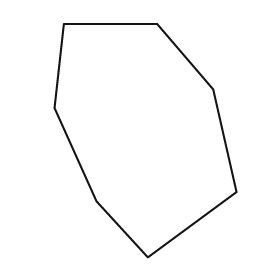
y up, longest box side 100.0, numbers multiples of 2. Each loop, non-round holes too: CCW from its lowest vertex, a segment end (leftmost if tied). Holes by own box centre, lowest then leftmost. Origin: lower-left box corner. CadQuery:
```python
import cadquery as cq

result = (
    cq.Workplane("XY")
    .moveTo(40.0, 0.0)
    .lineTo(78.0, 28.0)
    .lineTo(68.0, 72.0)
    .lineTo(44.0, 100.0)
    .lineTo(4.0, 100.0)
    .lineTo(0.0, 64.0)
    .lineTo(18.0, 24.0)
    .close()
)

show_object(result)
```